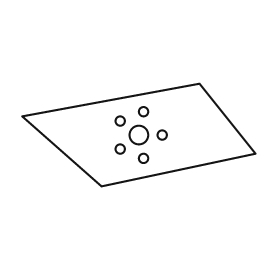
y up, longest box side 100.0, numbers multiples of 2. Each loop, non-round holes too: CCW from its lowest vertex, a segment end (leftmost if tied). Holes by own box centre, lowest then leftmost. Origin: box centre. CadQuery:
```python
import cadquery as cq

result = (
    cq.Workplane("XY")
    .moveTo(-16.0, -22.0)
    .lineTo(50.0, -8.0)
    .lineTo(26.0, 22.0)
    .lineTo(-50.0, 8.0)
    .close()
    .moveTo(2.0, -10.0)
    .circle(2.0)
    .moveTo(-8.0, -6.0)
    .circle(2.0)
    .moveTo(0.0, 0.0)
    .circle(4.0)
    .moveTo(10.0, 0.0)
    .circle(2.0)
    .moveTo(-8.0, 6.0)
    .circle(2.0)
    .moveTo(2.0, 10.0)
    .circle(2.0)
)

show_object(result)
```